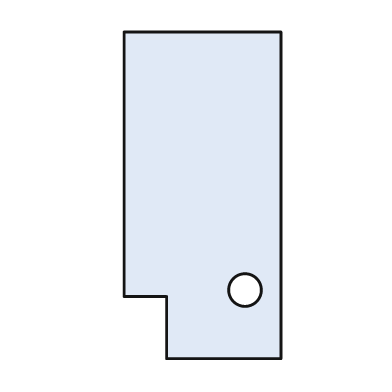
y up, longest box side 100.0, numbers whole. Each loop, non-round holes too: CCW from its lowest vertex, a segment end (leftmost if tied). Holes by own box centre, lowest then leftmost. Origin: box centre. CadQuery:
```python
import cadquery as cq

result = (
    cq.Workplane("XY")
    .moveTo(-11.0, -50.0)
    .lineTo(24.0, -50.0)
    .lineTo(24.0, 50.0)
    .lineTo(-24.0, 50.0)
    .lineTo(-24.0, -31.0)
    .lineTo(-11.0, -31.0)
    .close()
    .moveTo(13.0, -29.0)
    .circle(5.0)
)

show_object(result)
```